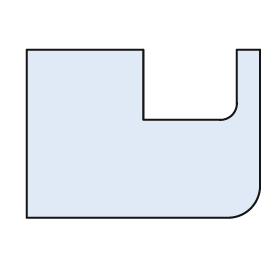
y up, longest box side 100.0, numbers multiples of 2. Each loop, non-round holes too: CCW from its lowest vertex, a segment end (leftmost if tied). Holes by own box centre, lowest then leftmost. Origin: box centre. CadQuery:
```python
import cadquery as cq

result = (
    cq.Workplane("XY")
    .moveTo(-50.0, -36.0)
    .lineTo(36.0, -36.0)
    .threePointArc((46.0, -32.0), (50.0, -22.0))
    .lineTo(50.0, 36.0)
    .lineTo(40.0, 36.0)
    .lineTo(40.0, 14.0)
    .threePointArc((38.0, 8.0), (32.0, 6.0))
    .lineTo(0.0, 6.0)
    .lineTo(0.0, 36.0)
    .lineTo(-50.0, 36.0)
    .close()
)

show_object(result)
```